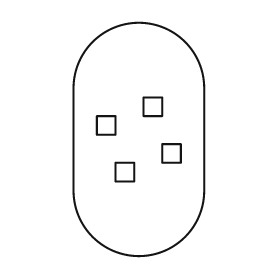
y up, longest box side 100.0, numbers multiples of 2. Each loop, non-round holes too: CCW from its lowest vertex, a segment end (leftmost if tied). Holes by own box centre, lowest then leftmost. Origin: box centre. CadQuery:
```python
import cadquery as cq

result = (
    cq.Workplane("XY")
    .moveTo(-28.0, -22.0)
    .threePointArc((0.0, -50.0), (28.0, -22.0))
    .lineTo(28.0, 22.0)
    .threePointArc((0.0, 50.0), (-28.0, 22.0))
    .close()
    .moveTo(-10.0, -18.0)
    .lineTo(-2.0, -18.0)
    .lineTo(-2.0, -10.0)
    .lineTo(-10.0, -10.0)
    .close()
    .moveTo(10.0, -10.0)
    .lineTo(18.0, -10.0)
    .lineTo(18.0, -2.0)
    .lineTo(10.0, -2.0)
    .close()
    .moveTo(-18.0, 2.0)
    .lineTo(-10.0, 2.0)
    .lineTo(-10.0, 10.0)
    .lineTo(-18.0, 10.0)
    .close()
    .moveTo(2.0, 10.0)
    .lineTo(10.0, 10.0)
    .lineTo(10.0, 18.0)
    .lineTo(2.0, 18.0)
    .close()
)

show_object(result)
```